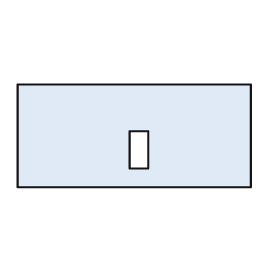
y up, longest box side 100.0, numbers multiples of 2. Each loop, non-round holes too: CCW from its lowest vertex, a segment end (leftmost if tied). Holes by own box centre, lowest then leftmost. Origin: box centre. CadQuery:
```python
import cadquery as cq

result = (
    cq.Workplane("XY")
    .moveTo(-50.0, -22.0)
    .lineTo(50.0, -22.0)
    .lineTo(50.0, 22.0)
    .lineTo(-50.0, 22.0)
    .close()
    .moveTo(-2.0, -14.0)
    .lineTo(6.0, -14.0)
    .lineTo(6.0, 2.0)
    .lineTo(-2.0, 2.0)
    .close()
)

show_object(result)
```